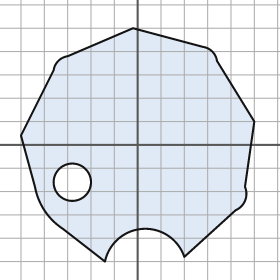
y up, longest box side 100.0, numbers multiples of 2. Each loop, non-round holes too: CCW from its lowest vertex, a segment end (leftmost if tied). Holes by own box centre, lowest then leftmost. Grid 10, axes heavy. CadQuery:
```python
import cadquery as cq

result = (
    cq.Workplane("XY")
    .moveTo(-14.0, -50.0)
    .threePointArc((2.0, -36.0), (20.0, -48.0))
    .lineTo(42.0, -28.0)
    .threePointArc((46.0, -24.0), (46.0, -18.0))
    .lineTo(50.0, 10.0)
    .lineTo(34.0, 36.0)
    .threePointArc((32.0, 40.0), (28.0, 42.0))
    .lineTo(-2.0, 50.0)
    .lineTo(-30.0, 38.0)
    .threePointArc((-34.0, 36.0), (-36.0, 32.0))
    .lineTo(-50.0, 4.0)
    .lineTo(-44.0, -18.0)
    .threePointArc((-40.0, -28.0), (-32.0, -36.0))
    .close()
    .moveTo(-28.0, -16.0)
    .circle(8.0)
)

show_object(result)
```